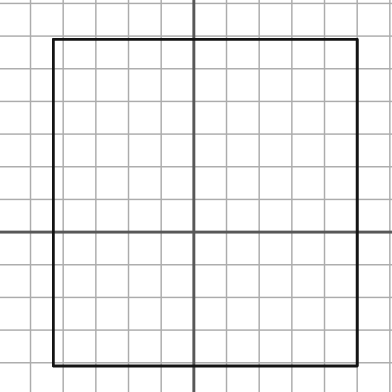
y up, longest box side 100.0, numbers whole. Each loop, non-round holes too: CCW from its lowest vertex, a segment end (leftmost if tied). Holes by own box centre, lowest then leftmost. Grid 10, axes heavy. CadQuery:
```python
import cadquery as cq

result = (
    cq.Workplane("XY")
    .moveTo(-43.0, -41.0)
    .lineTo(50.0, -41.0)
    .lineTo(50.0, 59.0)
    .lineTo(-43.0, 59.0)
    .close()
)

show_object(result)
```